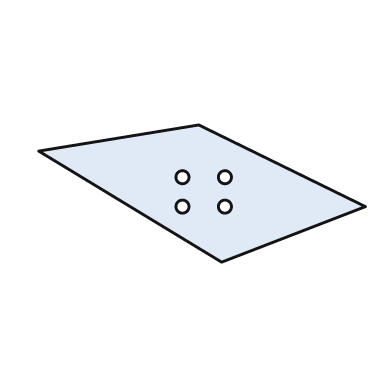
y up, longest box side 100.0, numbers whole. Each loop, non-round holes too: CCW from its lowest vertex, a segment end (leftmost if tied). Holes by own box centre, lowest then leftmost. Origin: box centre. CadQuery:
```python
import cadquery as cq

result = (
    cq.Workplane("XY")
    .moveTo(6.0, -21.0)
    .lineTo(50.0, -4.0)
    .lineTo(-1.0, 21.0)
    .lineTo(-50.0, 13.0)
    .close()
    .moveTo(-6.0, -4.0)
    .circle(2.0)
    .moveTo(7.0, -4.0)
    .circle(2.0)
    .moveTo(-6.0, 5.0)
    .circle(2.0)
    .moveTo(7.0, 5.0)
    .circle(2.0)
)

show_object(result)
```